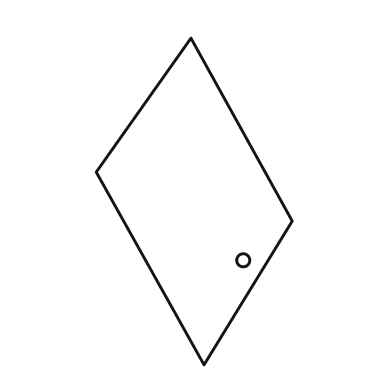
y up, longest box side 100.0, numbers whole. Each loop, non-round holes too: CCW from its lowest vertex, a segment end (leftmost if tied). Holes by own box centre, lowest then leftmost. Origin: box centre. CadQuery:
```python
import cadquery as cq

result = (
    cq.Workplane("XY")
    .moveTo(3.0, -50.0)
    .lineTo(30.0, -6.0)
    .lineTo(-1.0, 50.0)
    .lineTo(-30.0, 9.0)
    .close()
    .moveTo(15.0, -18.0)
    .circle(2.0)
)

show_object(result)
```